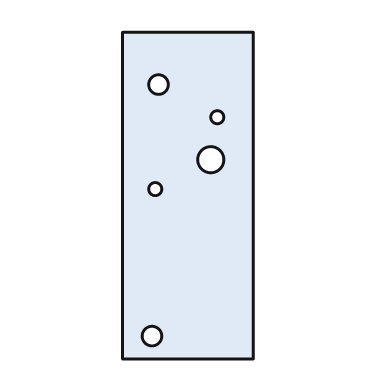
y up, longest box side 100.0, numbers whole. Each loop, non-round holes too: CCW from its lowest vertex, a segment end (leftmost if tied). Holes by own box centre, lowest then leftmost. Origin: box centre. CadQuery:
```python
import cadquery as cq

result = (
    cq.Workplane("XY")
    .moveTo(-20.0, -50.0)
    .lineTo(20.0, -50.0)
    .lineTo(20.0, 50.0)
    .lineTo(-20.0, 50.0)
    .close()
    .moveTo(-11.0, -43.0)
    .circle(3.0)
    .moveTo(-10.0, 2.0)
    .circle(2.0)
    .moveTo(7.0, 11.0)
    .circle(4.0)
    .moveTo(9.0, 24.0)
    .circle(2.0)
    .moveTo(-9.0, 34.0)
    .circle(3.0)
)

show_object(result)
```